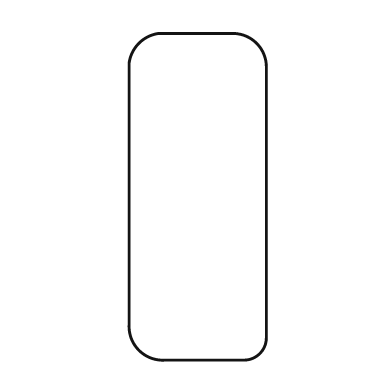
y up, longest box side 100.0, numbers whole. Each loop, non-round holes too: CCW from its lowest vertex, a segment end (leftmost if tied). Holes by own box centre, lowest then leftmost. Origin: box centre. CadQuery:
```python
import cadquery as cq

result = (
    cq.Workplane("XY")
    .moveTo(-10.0, -50.0)
    .lineTo(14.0, -50.0)
    .threePointArc((19.0, -48.0), (21.0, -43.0))
    .lineTo(21.0, 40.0)
    .threePointArc((18.0, 47.0), (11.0, 50.0))
    .lineTo(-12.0, 50.0)
    .threePointArc((-18.0, 47.0), (-21.0, 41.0))
    .lineTo(-21.0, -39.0)
    .threePointArc((-18.0, -47.0), (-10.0, -50.0))
    .close()
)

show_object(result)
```